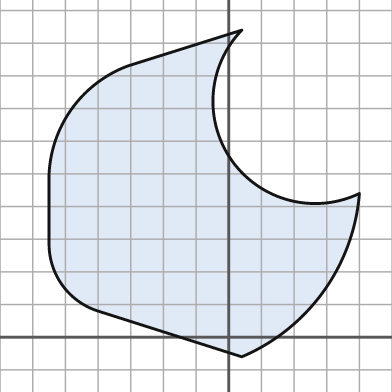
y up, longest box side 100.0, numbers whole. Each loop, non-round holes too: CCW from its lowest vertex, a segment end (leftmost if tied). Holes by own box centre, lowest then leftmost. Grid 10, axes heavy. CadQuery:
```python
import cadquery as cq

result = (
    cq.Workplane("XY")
    .moveTo(4.0, -6.0)
    .threePointArc((29.0, 14.0), (40.0, 44.0))
    .threePointArc((1.0, 54.0), (4.0, 94.0))
    .lineTo(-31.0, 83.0)
    .threePointArc((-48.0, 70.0), (-55.0, 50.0))
    .lineTo(-55.0, 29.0)
    .threePointArc((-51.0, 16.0), (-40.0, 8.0))
    .close()
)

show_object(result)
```